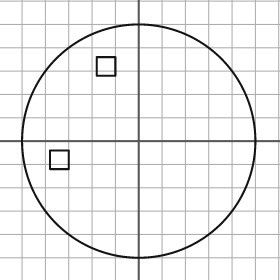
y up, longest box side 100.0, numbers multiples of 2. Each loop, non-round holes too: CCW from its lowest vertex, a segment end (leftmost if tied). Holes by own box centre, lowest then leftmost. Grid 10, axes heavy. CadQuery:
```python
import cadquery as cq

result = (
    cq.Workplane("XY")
    .moveTo(0.0, 0.0)
    .circle(50.0)
    .moveTo(-38.0, -12.0)
    .lineTo(-30.0, -12.0)
    .lineTo(-30.0, -4.0)
    .lineTo(-38.0, -4.0)
    .close()
    .moveTo(-18.0, 28.0)
    .lineTo(-10.0, 28.0)
    .lineTo(-10.0, 36.0)
    .lineTo(-18.0, 36.0)
    .close()
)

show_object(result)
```